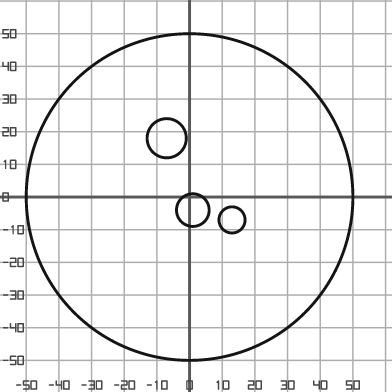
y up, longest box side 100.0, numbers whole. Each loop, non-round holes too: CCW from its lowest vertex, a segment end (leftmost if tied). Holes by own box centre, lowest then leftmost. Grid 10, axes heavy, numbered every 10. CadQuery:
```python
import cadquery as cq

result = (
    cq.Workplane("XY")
    .moveTo(0.0, 0.0)
    .circle(50.0)
    .moveTo(13.0, -7.0)
    .circle(4.0)
    .moveTo(1.0, -4.0)
    .circle(5.0)
    .moveTo(-7.0, 18.0)
    .circle(6.0)
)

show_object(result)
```